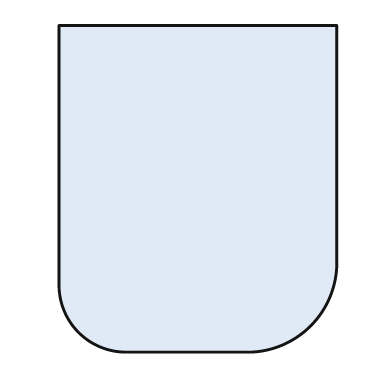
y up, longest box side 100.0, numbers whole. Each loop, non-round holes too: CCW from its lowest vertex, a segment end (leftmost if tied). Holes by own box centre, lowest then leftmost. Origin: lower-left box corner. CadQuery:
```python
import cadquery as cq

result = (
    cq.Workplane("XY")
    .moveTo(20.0, 0.0)
    .lineTo(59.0, 0.0)
    .threePointArc((77.0, 8.0), (85.0, 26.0))
    .lineTo(85.0, 100.0)
    .lineTo(0.0, 100.0)
    .lineTo(0.0, 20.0)
    .threePointArc((6.0, 6.0), (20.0, 0.0))
    .close()
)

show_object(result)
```